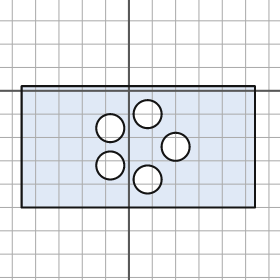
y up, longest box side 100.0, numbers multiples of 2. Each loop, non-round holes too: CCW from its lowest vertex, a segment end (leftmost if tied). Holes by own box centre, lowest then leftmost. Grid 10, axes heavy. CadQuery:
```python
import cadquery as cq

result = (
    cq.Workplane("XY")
    .moveTo(-46.0, -50.0)
    .lineTo(54.0, -50.0)
    .lineTo(54.0, 2.0)
    .lineTo(-46.0, 2.0)
    .close()
    .moveTo(8.0, -38.0)
    .circle(6.0)
    .moveTo(-8.0, -32.0)
    .circle(6.0)
    .moveTo(20.0, -24.0)
    .circle(6.0)
    .moveTo(-8.0, -16.0)
    .circle(6.0)
    .moveTo(8.0, -10.0)
    .circle(6.0)
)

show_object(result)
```